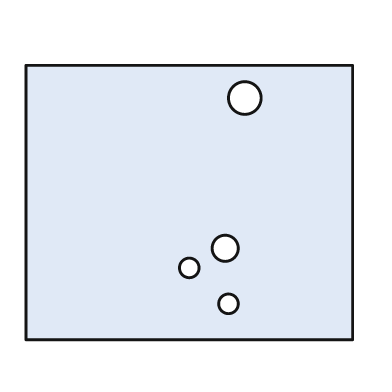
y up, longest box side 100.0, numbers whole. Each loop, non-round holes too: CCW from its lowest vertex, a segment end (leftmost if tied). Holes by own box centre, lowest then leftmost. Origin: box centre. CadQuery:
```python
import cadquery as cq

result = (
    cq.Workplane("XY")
    .moveTo(-50.0, -42.0)
    .lineTo(50.0, -42.0)
    .lineTo(50.0, 42.0)
    .lineTo(-50.0, 42.0)
    .close()
    .moveTo(12.0, -31.0)
    .circle(3.0)
    .moveTo(0.0, -20.0)
    .circle(3.0)
    .moveTo(11.0, -14.0)
    .circle(4.0)
    .moveTo(17.0, 32.0)
    .circle(5.0)
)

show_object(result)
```